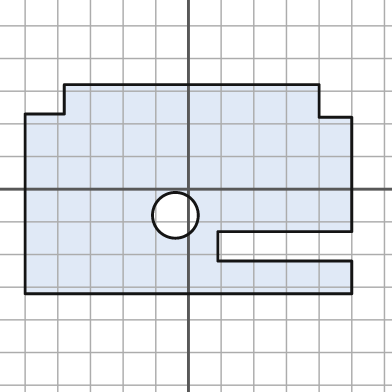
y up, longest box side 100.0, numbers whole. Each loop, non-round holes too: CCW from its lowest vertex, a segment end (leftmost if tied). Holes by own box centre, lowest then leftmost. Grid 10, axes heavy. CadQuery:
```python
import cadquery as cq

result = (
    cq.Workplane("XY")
    .moveTo(-50.0, -32.0)
    .lineTo(50.0, -32.0)
    .lineTo(50.0, -22.0)
    .lineTo(9.0, -22.0)
    .lineTo(9.0, -13.0)
    .lineTo(50.0, -13.0)
    .lineTo(50.0, 22.0)
    .lineTo(40.0, 22.0)
    .lineTo(40.0, 32.0)
    .lineTo(-38.0, 32.0)
    .lineTo(-38.0, 23.0)
    .lineTo(-50.0, 23.0)
    .close()
    .moveTo(-4.0, -8.0)
    .circle(7.0)
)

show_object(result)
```